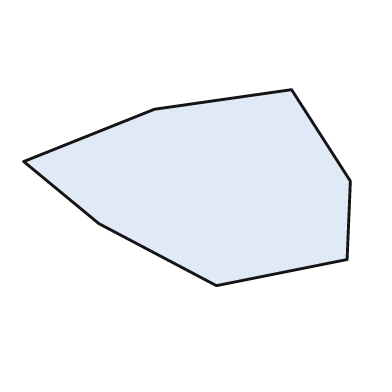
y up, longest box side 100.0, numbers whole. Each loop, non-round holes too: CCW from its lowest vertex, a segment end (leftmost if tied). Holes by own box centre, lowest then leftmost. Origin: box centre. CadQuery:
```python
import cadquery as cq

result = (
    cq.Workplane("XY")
    .moveTo(9.0, -30.0)
    .lineTo(49.0, -22.0)
    .lineTo(50.0, 2.0)
    .lineTo(32.0, 30.0)
    .lineTo(-10.0, 24.0)
    .lineTo(-50.0, 8.0)
    .lineTo(-27.0, -11.0)
    .close()
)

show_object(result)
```